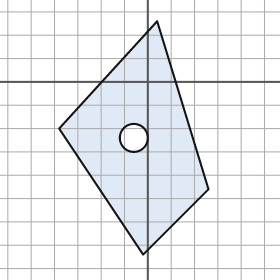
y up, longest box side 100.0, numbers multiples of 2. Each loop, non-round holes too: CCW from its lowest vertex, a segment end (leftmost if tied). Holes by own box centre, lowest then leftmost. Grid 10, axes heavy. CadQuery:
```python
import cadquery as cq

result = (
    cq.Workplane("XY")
    .moveTo(-2.0, -74.0)
    .lineTo(26.0, -46.0)
    .lineTo(4.0, 26.0)
    .lineTo(-38.0, -20.0)
    .close()
    .moveTo(-6.0, -24.0)
    .circle(6.0)
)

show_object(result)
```